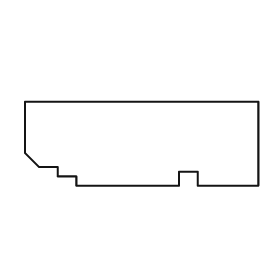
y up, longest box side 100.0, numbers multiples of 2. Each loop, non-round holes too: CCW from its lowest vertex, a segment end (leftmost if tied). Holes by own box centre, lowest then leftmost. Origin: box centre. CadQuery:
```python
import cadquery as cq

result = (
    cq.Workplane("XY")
    .moveTo(-28.0, -18.0)
    .lineTo(16.0, -18.0)
    .lineTo(16.0, -12.0)
    .lineTo(24.0, -12.0)
    .lineTo(24.0, -18.0)
    .lineTo(50.0, -18.0)
    .lineTo(50.0, 18.0)
    .lineTo(-50.0, 18.0)
    .lineTo(-50.0, -4.0)
    .lineTo(-44.0, -10.0)
    .lineTo(-36.0, -10.0)
    .lineTo(-36.0, -14.0)
    .lineTo(-28.0, -14.0)
    .close()
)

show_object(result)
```